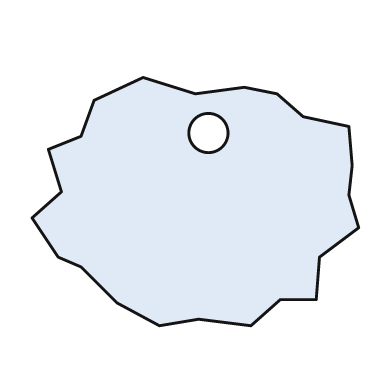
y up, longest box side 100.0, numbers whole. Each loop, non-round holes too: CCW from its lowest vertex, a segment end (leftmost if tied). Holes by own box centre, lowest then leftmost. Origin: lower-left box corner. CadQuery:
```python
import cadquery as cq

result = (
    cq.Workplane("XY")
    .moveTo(39.0, 0.0)
    .lineTo(51.0, 2.0)
    .lineTo(67.0, 0.0)
    .lineTo(76.0, 8.0)
    .lineTo(87.0, 8.0)
    .lineTo(88.0, 21.0)
    .lineTo(100.0, 30.0)
    .lineTo(97.0, 40.0)
    .lineTo(98.0, 49.0)
    .lineTo(97.0, 61.0)
    .lineTo(83.0, 64.0)
    .lineTo(75.0, 71.0)
    .lineTo(65.0, 73.0)
    .lineTo(50.0, 71.0)
    .lineTo(34.0, 76.0)
    .lineTo(19.0, 69.0)
    .lineTo(15.0, 58.0)
    .lineTo(5.0, 54.0)
    .lineTo(9.0, 41.0)
    .lineTo(0.0, 33.0)
    .lineTo(8.0, 21.0)
    .lineTo(15.0, 18.0)
    .lineTo(26.0, 7.0)
    .close()
    .moveTo(54.0, 59.0)
    .circle(6.0)
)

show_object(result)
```